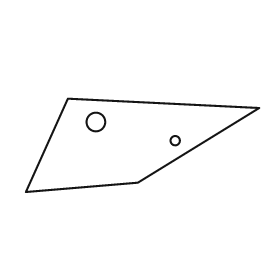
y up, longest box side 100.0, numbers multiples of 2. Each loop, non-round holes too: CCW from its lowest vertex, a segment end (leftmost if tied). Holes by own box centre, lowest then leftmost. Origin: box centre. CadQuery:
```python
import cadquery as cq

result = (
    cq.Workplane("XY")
    .moveTo(-50.0, -20.0)
    .lineTo(-2.0, -16.0)
    .lineTo(50.0, 16.0)
    .lineTo(-32.0, 20.0)
    .close()
    .moveTo(14.0, 2.0)
    .circle(2.0)
    .moveTo(-20.0, 10.0)
    .circle(4.0)
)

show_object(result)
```